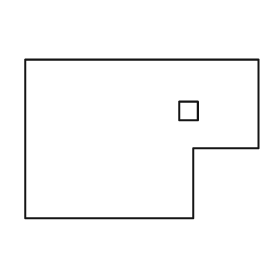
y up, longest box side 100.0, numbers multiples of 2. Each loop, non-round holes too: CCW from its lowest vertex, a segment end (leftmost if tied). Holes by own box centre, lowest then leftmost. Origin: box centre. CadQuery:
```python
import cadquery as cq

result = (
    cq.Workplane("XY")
    .moveTo(-50.0, -34.0)
    .lineTo(22.0, -34.0)
    .lineTo(22.0, -4.0)
    .lineTo(50.0, -4.0)
    .lineTo(50.0, 34.0)
    .lineTo(-50.0, 34.0)
    .close()
    .moveTo(16.0, 8.0)
    .lineTo(24.0, 8.0)
    .lineTo(24.0, 16.0)
    .lineTo(16.0, 16.0)
    .close()
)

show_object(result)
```